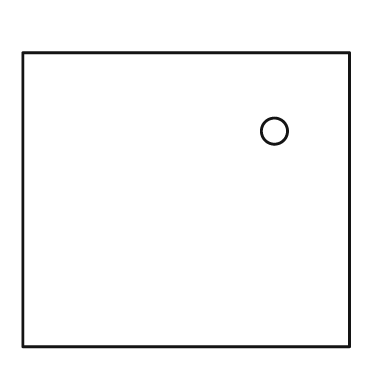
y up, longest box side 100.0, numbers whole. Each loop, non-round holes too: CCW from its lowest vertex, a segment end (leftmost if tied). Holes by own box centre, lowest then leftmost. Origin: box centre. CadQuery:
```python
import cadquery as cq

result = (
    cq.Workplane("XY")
    .moveTo(-50.0, -45.0)
    .lineTo(50.0, -45.0)
    .lineTo(50.0, 45.0)
    .lineTo(-50.0, 45.0)
    .close()
    .moveTo(27.0, 21.0)
    .circle(4.0)
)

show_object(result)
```